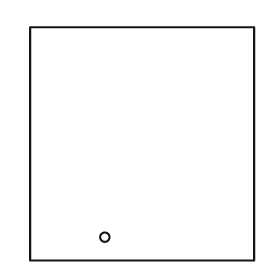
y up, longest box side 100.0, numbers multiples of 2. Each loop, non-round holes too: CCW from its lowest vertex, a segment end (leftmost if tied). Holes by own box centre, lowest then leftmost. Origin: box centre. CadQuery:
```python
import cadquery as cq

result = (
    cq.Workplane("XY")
    .moveTo(-48.0, -50.0)
    .lineTo(48.0, -50.0)
    .lineTo(48.0, 50.0)
    .lineTo(-48.0, 50.0)
    .close()
    .moveTo(-16.0, -40.0)
    .circle(2.0)
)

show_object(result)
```